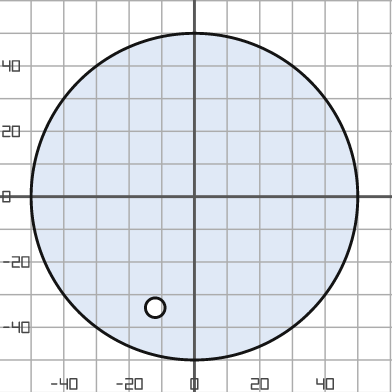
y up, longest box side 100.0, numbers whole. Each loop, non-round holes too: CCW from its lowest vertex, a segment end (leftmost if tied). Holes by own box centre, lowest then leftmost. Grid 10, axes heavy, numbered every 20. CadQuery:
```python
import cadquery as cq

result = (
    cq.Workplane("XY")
    .moveTo(0.0, 0.0)
    .circle(50.0)
    .moveTo(-12.0, -34.0)
    .circle(3.0)
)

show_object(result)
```